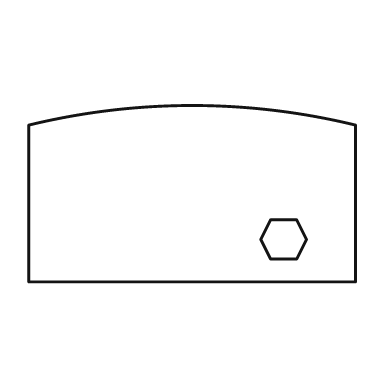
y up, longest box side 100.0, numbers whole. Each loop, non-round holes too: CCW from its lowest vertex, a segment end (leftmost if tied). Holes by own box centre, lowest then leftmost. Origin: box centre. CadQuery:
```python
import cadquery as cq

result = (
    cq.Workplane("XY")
    .moveTo(-50.0, -27.0)
    .lineTo(50.0, -27.0)
    .lineTo(50.0, 21.0)
    .threePointArc((0.0, 27.0), (-50.0, 21.0))
    .close()
    .moveTo(24.0, -20.0)
    .lineTo(32.0, -20.0)
    .lineTo(35.0, -14.0)
    .lineTo(32.0, -8.0)
    .lineTo(24.0, -8.0)
    .lineTo(21.0, -14.0)
    .close()
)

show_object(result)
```